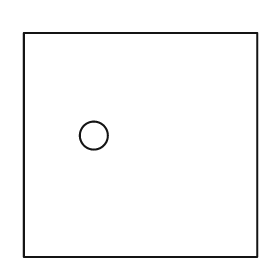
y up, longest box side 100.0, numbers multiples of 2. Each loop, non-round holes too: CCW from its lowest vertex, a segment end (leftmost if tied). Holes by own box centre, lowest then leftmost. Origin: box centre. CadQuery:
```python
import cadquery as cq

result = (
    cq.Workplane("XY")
    .moveTo(-50.0, -48.0)
    .lineTo(50.0, -48.0)
    .lineTo(50.0, 48.0)
    .lineTo(-50.0, 48.0)
    .close()
    .moveTo(-20.0, 4.0)
    .circle(6.0)
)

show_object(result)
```